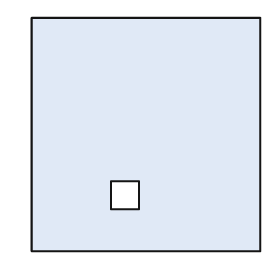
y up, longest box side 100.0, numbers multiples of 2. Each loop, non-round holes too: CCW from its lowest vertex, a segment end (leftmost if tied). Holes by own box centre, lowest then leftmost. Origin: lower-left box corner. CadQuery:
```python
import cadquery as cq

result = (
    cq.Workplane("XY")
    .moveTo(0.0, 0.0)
    .lineTo(98.0, 0.0)
    .lineTo(98.0, 100.0)
    .lineTo(0.0, 100.0)
    .close()
    .moveTo(34.0, 18.0)
    .lineTo(46.0, 18.0)
    .lineTo(46.0, 30.0)
    .lineTo(34.0, 30.0)
    .close()
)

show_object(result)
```